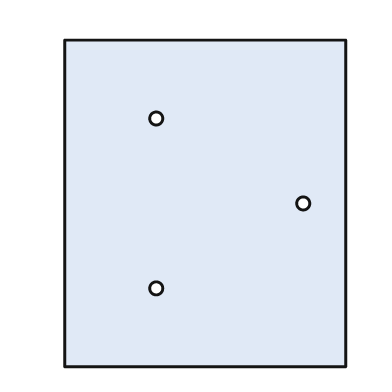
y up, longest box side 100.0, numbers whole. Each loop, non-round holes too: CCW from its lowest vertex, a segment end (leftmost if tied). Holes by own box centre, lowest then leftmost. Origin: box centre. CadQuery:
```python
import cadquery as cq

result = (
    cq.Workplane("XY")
    .moveTo(-43.0, -50.0)
    .lineTo(43.0, -50.0)
    .lineTo(43.0, 50.0)
    .lineTo(-43.0, 50.0)
    .close()
    .moveTo(-15.0, -26.0)
    .circle(2.0)
    .moveTo(30.0, 0.0)
    .circle(2.0)
    .moveTo(-15.0, 26.0)
    .circle(2.0)
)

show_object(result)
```